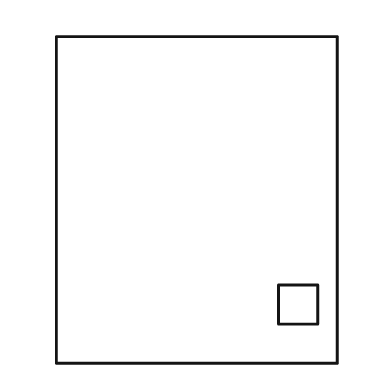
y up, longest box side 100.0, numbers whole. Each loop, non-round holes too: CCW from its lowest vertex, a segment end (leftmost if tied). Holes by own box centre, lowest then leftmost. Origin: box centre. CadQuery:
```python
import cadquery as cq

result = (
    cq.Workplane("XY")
    .moveTo(-43.0, -50.0)
    .lineTo(43.0, -50.0)
    .lineTo(43.0, 50.0)
    .lineTo(-43.0, 50.0)
    .close()
    .moveTo(25.0, -38.0)
    .lineTo(37.0, -38.0)
    .lineTo(37.0, -26.0)
    .lineTo(25.0, -26.0)
    .close()
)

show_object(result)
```